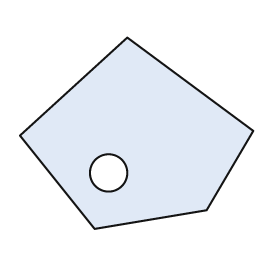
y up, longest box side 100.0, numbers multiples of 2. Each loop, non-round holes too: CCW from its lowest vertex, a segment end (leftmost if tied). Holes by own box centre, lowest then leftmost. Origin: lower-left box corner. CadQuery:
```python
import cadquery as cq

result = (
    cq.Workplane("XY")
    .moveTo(32.0, 0.0)
    .lineTo(80.0, 8.0)
    .lineTo(100.0, 42.0)
    .lineTo(46.0, 82.0)
    .lineTo(0.0, 40.0)
    .close()
    .moveTo(38.0, 24.0)
    .circle(8.0)
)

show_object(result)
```